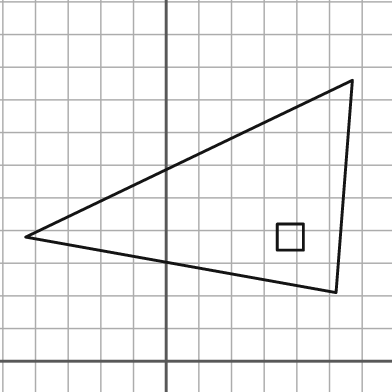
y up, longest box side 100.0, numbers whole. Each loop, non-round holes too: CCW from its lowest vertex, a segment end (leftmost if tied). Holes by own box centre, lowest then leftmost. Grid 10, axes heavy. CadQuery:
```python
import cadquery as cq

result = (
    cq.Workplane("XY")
    .moveTo(52.0, 21.0)
    .lineTo(57.0, 86.0)
    .lineTo(-43.0, 38.0)
    .close()
    .moveTo(34.0, 34.0)
    .lineTo(42.0, 34.0)
    .lineTo(42.0, 42.0)
    .lineTo(34.0, 42.0)
    .close()
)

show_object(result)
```